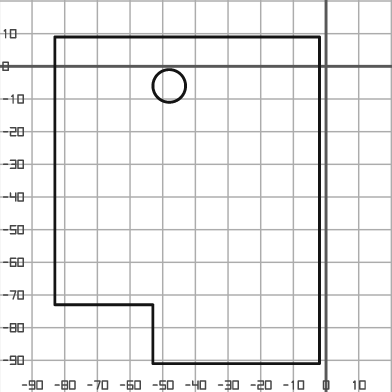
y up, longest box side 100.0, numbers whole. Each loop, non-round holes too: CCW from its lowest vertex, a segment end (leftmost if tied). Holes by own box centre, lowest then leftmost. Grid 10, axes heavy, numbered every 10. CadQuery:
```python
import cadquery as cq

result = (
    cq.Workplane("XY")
    .moveTo(-53.0, -91.0)
    .lineTo(-2.0, -91.0)
    .lineTo(-2.0, 9.0)
    .lineTo(-83.0, 9.0)
    .lineTo(-83.0, -73.0)
    .lineTo(-53.0, -73.0)
    .close()
    .moveTo(-48.0, -6.0)
    .circle(5.0)
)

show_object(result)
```